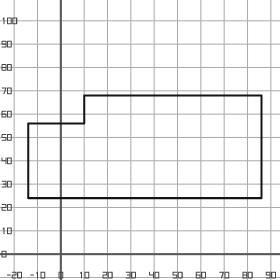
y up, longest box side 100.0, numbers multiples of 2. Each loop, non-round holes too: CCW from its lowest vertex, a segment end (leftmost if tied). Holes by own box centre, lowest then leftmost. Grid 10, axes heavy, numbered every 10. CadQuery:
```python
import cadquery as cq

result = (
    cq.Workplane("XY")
    .moveTo(-14.0, 24.0)
    .lineTo(86.0, 24.0)
    .lineTo(86.0, 68.0)
    .lineTo(10.0, 68.0)
    .lineTo(10.0, 56.0)
    .lineTo(-14.0, 56.0)
    .close()
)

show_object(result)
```